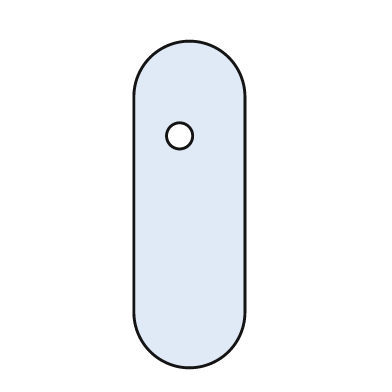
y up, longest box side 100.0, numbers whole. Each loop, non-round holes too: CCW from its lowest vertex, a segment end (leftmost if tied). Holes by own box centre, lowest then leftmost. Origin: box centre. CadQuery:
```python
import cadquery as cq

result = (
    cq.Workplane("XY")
    .moveTo(-17.0, -33.0)
    .threePointArc((0.0, -50.0), (17.0, -33.0))
    .lineTo(17.0, 33.0)
    .threePointArc((0.0, 50.0), (-17.0, 33.0))
    .close()
    .moveTo(-3.0, 21.0)
    .circle(4.0)
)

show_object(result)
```